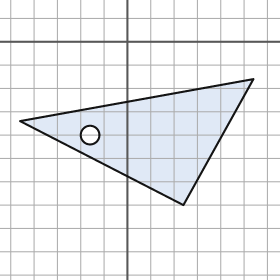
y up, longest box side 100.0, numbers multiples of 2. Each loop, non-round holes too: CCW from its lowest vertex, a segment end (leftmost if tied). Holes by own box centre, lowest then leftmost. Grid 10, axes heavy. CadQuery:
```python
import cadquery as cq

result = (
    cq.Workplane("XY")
    .moveTo(24.0, -70.0)
    .lineTo(54.0, -16.0)
    .lineTo(-46.0, -34.0)
    .close()
    .moveTo(-16.0, -40.0)
    .circle(4.0)
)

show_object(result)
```